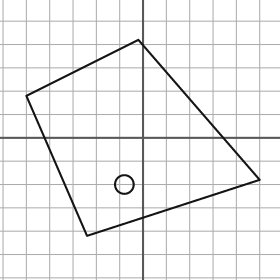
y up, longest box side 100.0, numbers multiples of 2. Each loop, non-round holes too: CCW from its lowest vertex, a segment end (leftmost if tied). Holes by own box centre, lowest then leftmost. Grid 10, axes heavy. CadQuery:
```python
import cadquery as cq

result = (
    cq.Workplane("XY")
    .moveTo(-24.0, -42.0)
    .lineTo(50.0, -18.0)
    .lineTo(-2.0, 42.0)
    .lineTo(-50.0, 18.0)
    .close()
    .moveTo(-8.0, -20.0)
    .circle(4.0)
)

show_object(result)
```